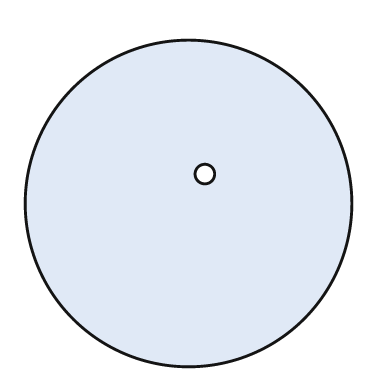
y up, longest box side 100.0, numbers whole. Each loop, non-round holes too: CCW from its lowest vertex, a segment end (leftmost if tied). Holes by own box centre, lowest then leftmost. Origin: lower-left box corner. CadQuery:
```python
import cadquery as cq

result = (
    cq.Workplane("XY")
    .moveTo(50.0, 50.0)
    .circle(50.0)
    .moveTo(55.0, 59.0)
    .circle(3.0)
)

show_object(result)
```